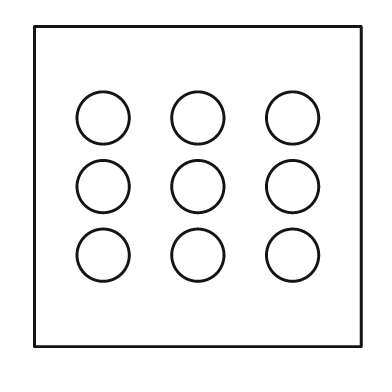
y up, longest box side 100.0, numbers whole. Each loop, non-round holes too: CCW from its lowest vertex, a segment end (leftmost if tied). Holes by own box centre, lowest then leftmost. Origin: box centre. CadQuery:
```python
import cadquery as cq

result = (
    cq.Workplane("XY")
    .moveTo(-50.0, -49.0)
    .lineTo(50.0, -49.0)
    .lineTo(50.0, 49.0)
    .lineTo(-50.0, 49.0)
    .close()
    .moveTo(-29.0, -21.0)
    .circle(8.0)
    .moveTo(0.0, -21.0)
    .circle(8.0)
    .moveTo(29.0, -21.0)
    .circle(8.0)
    .moveTo(-29.0, 0.0)
    .circle(8.0)
    .moveTo(0.0, 0.0)
    .circle(8.0)
    .moveTo(29.0, 0.0)
    .circle(8.0)
    .moveTo(-29.0, 21.0)
    .circle(8.0)
    .moveTo(0.0, 21.0)
    .circle(8.0)
    .moveTo(29.0, 21.0)
    .circle(8.0)
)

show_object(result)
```